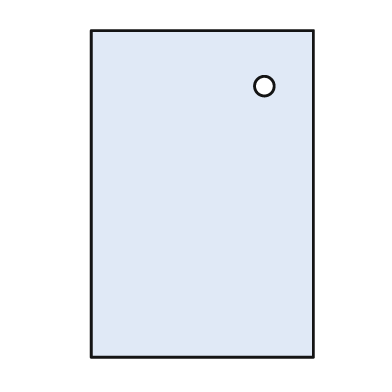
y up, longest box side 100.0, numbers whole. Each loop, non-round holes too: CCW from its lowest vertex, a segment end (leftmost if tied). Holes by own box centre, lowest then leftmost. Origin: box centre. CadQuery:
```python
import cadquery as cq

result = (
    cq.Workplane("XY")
    .moveTo(-34.0, -50.0)
    .lineTo(34.0, -50.0)
    .lineTo(34.0, 50.0)
    .lineTo(-34.0, 50.0)
    .close()
    .moveTo(19.0, 33.0)
    .circle(3.0)
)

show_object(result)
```